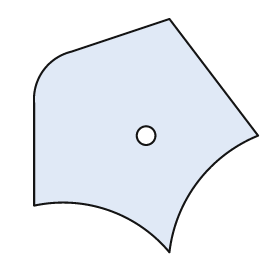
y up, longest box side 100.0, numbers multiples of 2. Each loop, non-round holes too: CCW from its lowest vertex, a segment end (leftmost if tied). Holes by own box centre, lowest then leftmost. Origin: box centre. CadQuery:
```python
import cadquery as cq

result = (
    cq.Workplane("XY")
    .moveTo(10.0, -50.0)
    .threePointArc((22.0, -20.0), (48.0, 0.0))
    .lineTo(10.0, 50.0)
    .lineTo(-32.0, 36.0)
    .threePointArc((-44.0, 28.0), (-48.0, 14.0))
    .lineTo(-48.0, -30.0)
    .threePointArc((-16.0, -32.0), (10.0, -50.0))
    .close()
    .moveTo(0.0, 0.0)
    .circle(4.0)
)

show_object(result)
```